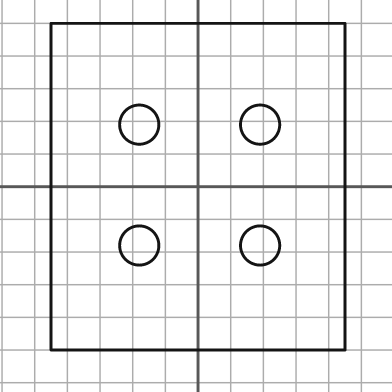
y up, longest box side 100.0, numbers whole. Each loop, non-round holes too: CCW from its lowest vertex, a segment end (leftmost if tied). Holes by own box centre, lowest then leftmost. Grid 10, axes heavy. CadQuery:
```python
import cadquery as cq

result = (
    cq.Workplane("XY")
    .moveTo(-45.0, -50.0)
    .lineTo(45.0, -50.0)
    .lineTo(45.0, 50.0)
    .lineTo(-45.0, 50.0)
    .close()
    .moveTo(-18.0, -18.0)
    .circle(6.0)
    .moveTo(19.0, -18.0)
    .circle(6.0)
    .moveTo(-18.0, 19.0)
    .circle(6.0)
    .moveTo(19.0, 19.0)
    .circle(6.0)
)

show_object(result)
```